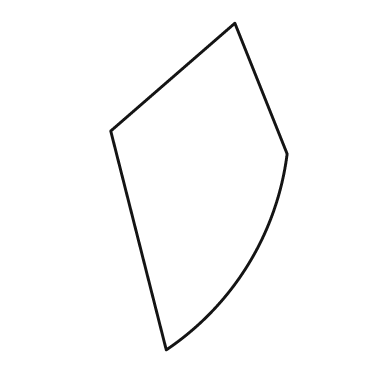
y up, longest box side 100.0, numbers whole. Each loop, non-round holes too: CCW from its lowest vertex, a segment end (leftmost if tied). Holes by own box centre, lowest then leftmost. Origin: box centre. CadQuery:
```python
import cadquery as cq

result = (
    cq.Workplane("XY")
    .moveTo(-10.0, -50.0)
    .threePointArc((15.0, -24.0), (27.0, 10.0))
    .lineTo(11.0, 50.0)
    .lineTo(-27.0, 17.0)
    .close()
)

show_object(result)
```